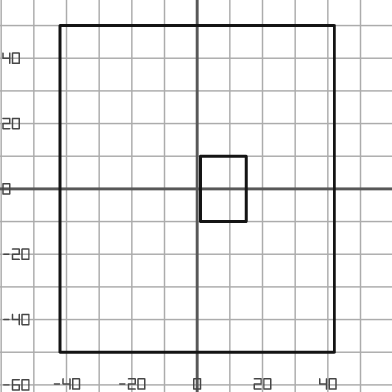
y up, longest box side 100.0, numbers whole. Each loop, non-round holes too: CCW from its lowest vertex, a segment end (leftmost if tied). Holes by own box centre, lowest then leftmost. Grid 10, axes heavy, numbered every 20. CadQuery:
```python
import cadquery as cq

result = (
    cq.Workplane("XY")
    .moveTo(-42.0, -50.0)
    .lineTo(42.0, -50.0)
    .lineTo(42.0, 50.0)
    .lineTo(-42.0, 50.0)
    .close()
    .moveTo(1.0, -10.0)
    .lineTo(15.0, -10.0)
    .lineTo(15.0, 10.0)
    .lineTo(1.0, 10.0)
    .close()
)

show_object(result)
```